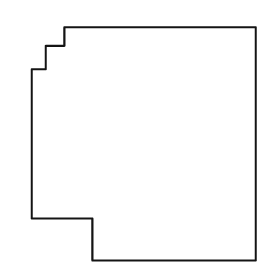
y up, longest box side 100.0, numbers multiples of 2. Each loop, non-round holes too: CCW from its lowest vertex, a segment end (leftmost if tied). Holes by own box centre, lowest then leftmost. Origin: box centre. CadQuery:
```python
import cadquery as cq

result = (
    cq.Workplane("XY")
    .moveTo(-22.0, -50.0)
    .lineTo(48.0, -50.0)
    .lineTo(48.0, 50.0)
    .lineTo(-34.0, 50.0)
    .lineTo(-34.0, 42.0)
    .lineTo(-42.0, 42.0)
    .lineTo(-42.0, 32.0)
    .lineTo(-48.0, 32.0)
    .lineTo(-48.0, -32.0)
    .lineTo(-22.0, -32.0)
    .close()
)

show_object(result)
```